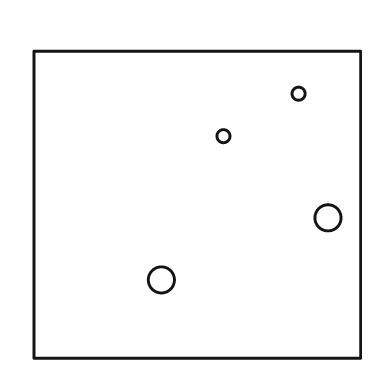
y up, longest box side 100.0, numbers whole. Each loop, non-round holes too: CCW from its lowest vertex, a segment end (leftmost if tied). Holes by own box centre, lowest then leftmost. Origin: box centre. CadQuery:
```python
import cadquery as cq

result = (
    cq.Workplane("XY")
    .moveTo(-50.0, -47.0)
    .lineTo(50.0, -47.0)
    .lineTo(50.0, 47.0)
    .lineTo(-50.0, 47.0)
    .close()
    .moveTo(-11.0, -23.0)
    .circle(4.0)
    .moveTo(40.0, -4.0)
    .circle(4.0)
    .moveTo(8.0, 21.0)
    .circle(2.0)
    .moveTo(31.0, 34.0)
    .circle(2.0)
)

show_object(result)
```